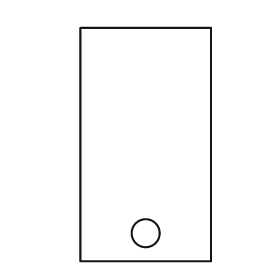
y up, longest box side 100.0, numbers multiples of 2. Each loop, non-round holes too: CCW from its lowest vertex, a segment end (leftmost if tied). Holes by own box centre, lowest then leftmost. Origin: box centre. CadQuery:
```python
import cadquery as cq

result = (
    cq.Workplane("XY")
    .moveTo(-28.0, -50.0)
    .lineTo(28.0, -50.0)
    .lineTo(28.0, 50.0)
    .lineTo(-28.0, 50.0)
    .close()
    .moveTo(0.0, -38.0)
    .circle(6.0)
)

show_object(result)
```